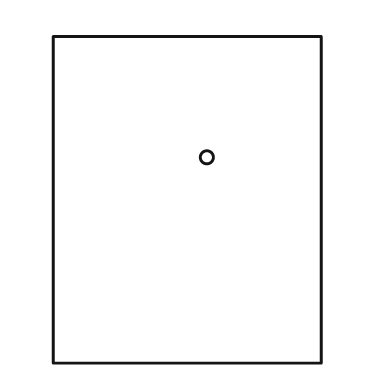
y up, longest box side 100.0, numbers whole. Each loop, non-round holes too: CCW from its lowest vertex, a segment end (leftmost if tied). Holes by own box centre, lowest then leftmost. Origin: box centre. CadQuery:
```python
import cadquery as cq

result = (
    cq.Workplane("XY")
    .moveTo(-41.0, -50.0)
    .lineTo(41.0, -50.0)
    .lineTo(41.0, 50.0)
    .lineTo(-41.0, 50.0)
    .close()
    .moveTo(6.0, 13.0)
    .circle(2.0)
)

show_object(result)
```